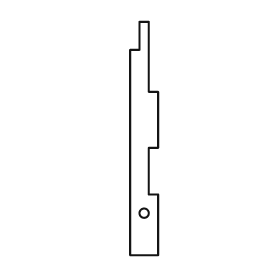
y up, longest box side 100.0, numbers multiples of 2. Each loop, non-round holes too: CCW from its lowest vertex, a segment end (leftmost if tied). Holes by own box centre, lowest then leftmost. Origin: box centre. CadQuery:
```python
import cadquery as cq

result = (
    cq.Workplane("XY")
    .moveTo(-6.0, -50.0)
    .lineTo(6.0, -50.0)
    .lineTo(6.0, -24.0)
    .lineTo(2.0, -24.0)
    .lineTo(2.0, -4.0)
    .lineTo(6.0, -4.0)
    .lineTo(6.0, 20.0)
    .lineTo(2.0, 20.0)
    .lineTo(2.0, 50.0)
    .lineTo(-2.0, 50.0)
    .lineTo(-2.0, 38.0)
    .lineTo(-6.0, 38.0)
    .close()
    .moveTo(0.0, -32.0)
    .circle(2.0)
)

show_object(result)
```